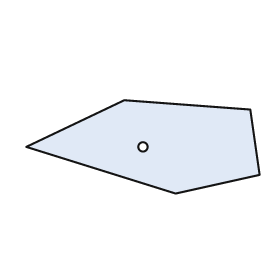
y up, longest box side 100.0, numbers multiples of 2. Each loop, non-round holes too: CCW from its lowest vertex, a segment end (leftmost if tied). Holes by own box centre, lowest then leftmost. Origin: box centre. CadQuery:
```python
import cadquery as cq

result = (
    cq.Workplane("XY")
    .moveTo(14.0, -20.0)
    .lineTo(50.0, -12.0)
    .lineTo(46.0, 16.0)
    .lineTo(-8.0, 20.0)
    .lineTo(-50.0, 0.0)
    .close()
    .moveTo(0.0, 0.0)
    .circle(2.0)
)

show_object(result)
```